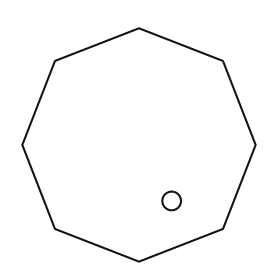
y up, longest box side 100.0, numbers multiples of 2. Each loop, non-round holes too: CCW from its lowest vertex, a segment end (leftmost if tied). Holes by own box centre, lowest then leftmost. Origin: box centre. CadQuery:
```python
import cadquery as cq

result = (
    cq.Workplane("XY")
    .moveTo(0.0, -50.0)
    .lineTo(36.0, -36.0)
    .lineTo(50.0, 0.0)
    .lineTo(36.0, 36.0)
    .lineTo(0.0, 50.0)
    .lineTo(-36.0, 36.0)
    .lineTo(-50.0, 0.0)
    .lineTo(-36.0, -36.0)
    .close()
    .moveTo(14.0, -24.0)
    .circle(4.0)
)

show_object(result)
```